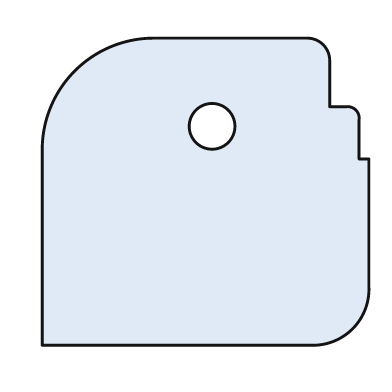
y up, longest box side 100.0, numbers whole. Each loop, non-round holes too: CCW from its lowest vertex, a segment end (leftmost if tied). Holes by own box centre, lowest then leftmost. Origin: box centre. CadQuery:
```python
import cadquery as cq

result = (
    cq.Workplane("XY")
    .moveTo(-50.0, -47.0)
    .lineTo(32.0, -47.0)
    .threePointArc((45.0, -42.0), (50.0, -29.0))
    .lineTo(50.0, 10.0)
    .lineTo(47.0, 10.0)
    .lineTo(47.0, 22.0)
    .threePointArc((46.0, 25.0), (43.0, 26.0))
    .lineTo(38.0, 26.0)
    .lineTo(38.0, 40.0)
    .threePointArc((36.0, 45.0), (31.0, 47.0))
    .lineTo(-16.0, 47.0)
    .threePointArc((-40.0, 37.0), (-50.0, 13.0))
    .close()
    .moveTo(2.0, 20.0)
    .circle(7.0)
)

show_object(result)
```